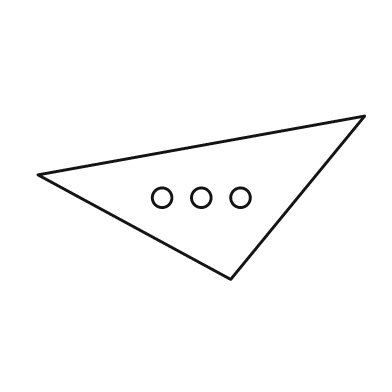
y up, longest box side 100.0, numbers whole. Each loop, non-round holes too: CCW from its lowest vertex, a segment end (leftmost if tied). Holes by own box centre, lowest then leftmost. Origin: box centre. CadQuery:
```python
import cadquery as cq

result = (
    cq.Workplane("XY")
    .moveTo(9.0, -25.0)
    .lineTo(50.0, 25.0)
    .lineTo(-50.0, 7.0)
    .close()
    .moveTo(-12.0, 0.0)
    .circle(3.0)
    .moveTo(0.0, 0.0)
    .circle(3.0)
    .moveTo(12.0, 0.0)
    .circle(3.0)
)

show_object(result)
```